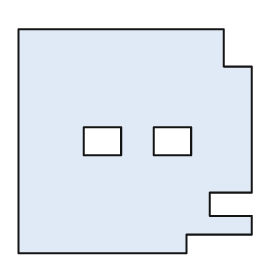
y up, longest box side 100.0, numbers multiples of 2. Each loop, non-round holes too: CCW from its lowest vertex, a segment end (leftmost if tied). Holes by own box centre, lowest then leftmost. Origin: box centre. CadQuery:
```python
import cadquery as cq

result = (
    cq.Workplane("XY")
    .moveTo(-50.0, -48.0)
    .lineTo(22.0, -48.0)
    .lineTo(22.0, -40.0)
    .lineTo(50.0, -40.0)
    .lineTo(50.0, -32.0)
    .lineTo(32.0, -32.0)
    .lineTo(32.0, -22.0)
    .lineTo(50.0, -22.0)
    .lineTo(50.0, 32.0)
    .lineTo(38.0, 32.0)
    .lineTo(38.0, 48.0)
    .lineTo(-50.0, 48.0)
    .close()
    .moveTo(-22.0, -6.0)
    .lineTo(-6.0, -6.0)
    .lineTo(-6.0, 6.0)
    .lineTo(-22.0, 6.0)
    .close()
    .moveTo(8.0, -6.0)
    .lineTo(24.0, -6.0)
    .lineTo(24.0, 6.0)
    .lineTo(8.0, 6.0)
    .close()
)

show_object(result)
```